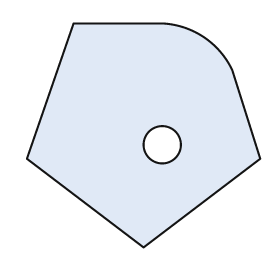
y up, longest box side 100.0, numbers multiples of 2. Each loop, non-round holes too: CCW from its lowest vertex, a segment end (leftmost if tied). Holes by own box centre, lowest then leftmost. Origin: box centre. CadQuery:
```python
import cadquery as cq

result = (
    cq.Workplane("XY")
    .moveTo(0.0, -48.0)
    .lineTo(50.0, -10.0)
    .lineTo(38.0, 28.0)
    .threePointArc((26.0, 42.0), (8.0, 48.0))
    .lineTo(-30.0, 48.0)
    .lineTo(-50.0, -10.0)
    .close()
    .moveTo(8.0, -4.0)
    .circle(8.0)
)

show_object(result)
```